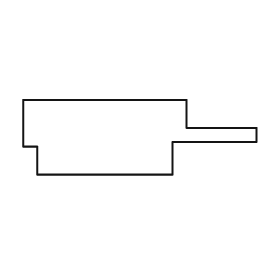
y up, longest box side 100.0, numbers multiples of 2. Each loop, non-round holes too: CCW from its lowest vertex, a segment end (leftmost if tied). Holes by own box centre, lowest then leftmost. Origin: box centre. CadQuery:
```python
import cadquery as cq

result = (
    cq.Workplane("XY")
    .moveTo(-44.0, -16.0)
    .lineTo(14.0, -16.0)
    .lineTo(14.0, -2.0)
    .lineTo(50.0, -2.0)
    .lineTo(50.0, 4.0)
    .lineTo(20.0, 4.0)
    .lineTo(20.0, 16.0)
    .lineTo(-50.0, 16.0)
    .lineTo(-50.0, -4.0)
    .lineTo(-44.0, -4.0)
    .close()
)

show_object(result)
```